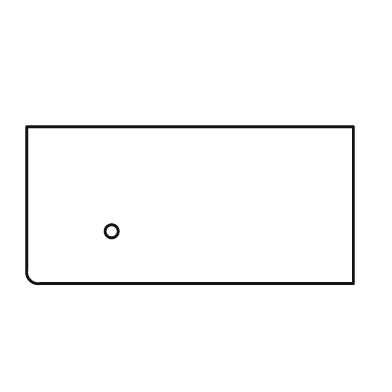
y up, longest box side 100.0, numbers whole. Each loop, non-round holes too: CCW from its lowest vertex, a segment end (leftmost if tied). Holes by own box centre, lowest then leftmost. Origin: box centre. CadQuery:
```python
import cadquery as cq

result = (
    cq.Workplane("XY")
    .moveTo(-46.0, -24.0)
    .lineTo(50.0, -24.0)
    .lineTo(50.0, 24.0)
    .lineTo(-50.0, 24.0)
    .lineTo(-50.0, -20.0)
    .threePointArc((-49.0, -23.0), (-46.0, -24.0))
    .close()
    .moveTo(-24.0, -8.0)
    .circle(2.0)
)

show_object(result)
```